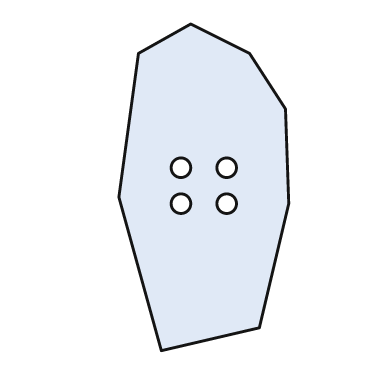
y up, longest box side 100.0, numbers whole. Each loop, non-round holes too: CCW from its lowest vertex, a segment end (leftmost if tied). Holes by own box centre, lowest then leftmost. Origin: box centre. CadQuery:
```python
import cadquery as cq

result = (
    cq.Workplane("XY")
    .moveTo(-13.0, -50.0)
    .lineTo(17.0, -43.0)
    .lineTo(26.0, -5.0)
    .lineTo(25.0, 24.0)
    .lineTo(14.0, 41.0)
    .lineTo(-4.0, 50.0)
    .lineTo(-20.0, 41.0)
    .lineTo(-26.0, -3.0)
    .close()
    .moveTo(-7.0, -5.0)
    .circle(3.0)
    .moveTo(7.0, -5.0)
    .circle(3.0)
    .moveTo(-7.0, 6.0)
    .circle(3.0)
    .moveTo(7.0, 6.0)
    .circle(3.0)
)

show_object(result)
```